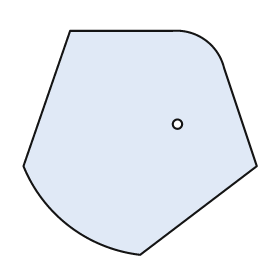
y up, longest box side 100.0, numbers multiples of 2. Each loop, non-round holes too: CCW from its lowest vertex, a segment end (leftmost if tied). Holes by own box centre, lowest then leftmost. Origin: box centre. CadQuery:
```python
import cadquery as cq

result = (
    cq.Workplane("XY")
    .moveTo(0.0, -48.0)
    .lineTo(50.0, -10.0)
    .lineTo(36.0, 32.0)
    .threePointArc((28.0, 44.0), (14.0, 48.0))
    .lineTo(-30.0, 48.0)
    .lineTo(-50.0, -10.0)
    .threePointArc((-30.0, -36.0), (0.0, -48.0))
    .close()
    .moveTo(16.0, 8.0)
    .circle(2.0)
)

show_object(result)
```